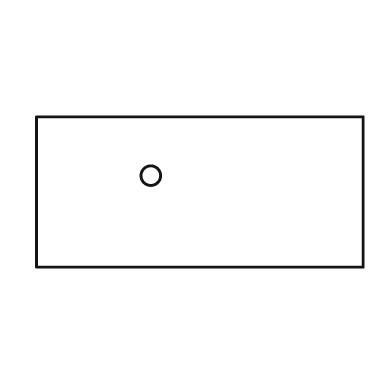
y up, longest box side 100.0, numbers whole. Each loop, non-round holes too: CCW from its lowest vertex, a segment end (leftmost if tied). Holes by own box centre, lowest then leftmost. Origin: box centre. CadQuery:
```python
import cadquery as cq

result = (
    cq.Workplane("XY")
    .moveTo(-50.0, -23.0)
    .lineTo(50.0, -23.0)
    .lineTo(50.0, 23.0)
    .lineTo(-50.0, 23.0)
    .close()
    .moveTo(-15.0, 5.0)
    .circle(3.0)
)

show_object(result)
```